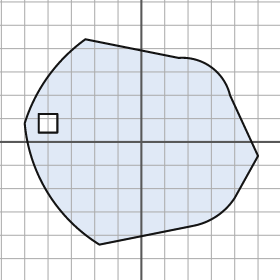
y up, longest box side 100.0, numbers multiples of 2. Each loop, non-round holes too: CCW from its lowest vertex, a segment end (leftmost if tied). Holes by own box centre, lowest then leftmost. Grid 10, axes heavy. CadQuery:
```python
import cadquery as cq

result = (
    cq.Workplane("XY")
    .moveTo(-18.0, -44.0)
    .lineTo(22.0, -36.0)
    .threePointArc((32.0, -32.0), (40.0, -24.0))
    .lineTo(50.0, -6.0)
    .lineTo(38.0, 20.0)
    .threePointArc((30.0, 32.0), (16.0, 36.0))
    .lineTo(-24.0, 44.0)
    .threePointArc((-40.0, 28.0), (-50.0, 8.0))
    .threePointArc((-40.0, -22.0), (-18.0, -44.0))
    .close()
    .moveTo(-44.0, 4.0)
    .lineTo(-36.0, 4.0)
    .lineTo(-36.0, 12.0)
    .lineTo(-44.0, 12.0)
    .close()
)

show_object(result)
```